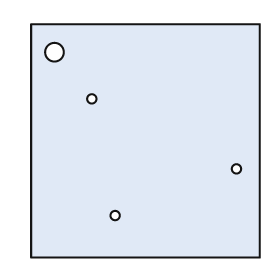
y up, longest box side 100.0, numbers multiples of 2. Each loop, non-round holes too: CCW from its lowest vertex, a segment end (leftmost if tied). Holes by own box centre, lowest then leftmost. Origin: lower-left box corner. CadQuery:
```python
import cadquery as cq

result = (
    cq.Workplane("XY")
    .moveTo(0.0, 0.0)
    .lineTo(98.0, 0.0)
    .lineTo(98.0, 100.0)
    .lineTo(0.0, 100.0)
    .close()
    .moveTo(36.0, 18.0)
    .circle(2.0)
    .moveTo(88.0, 38.0)
    .circle(2.0)
    .moveTo(26.0, 68.0)
    .circle(2.0)
    .moveTo(10.0, 88.0)
    .circle(4.0)
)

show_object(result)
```